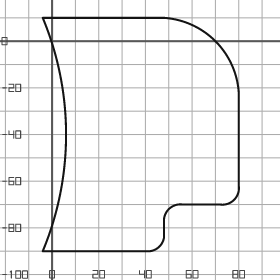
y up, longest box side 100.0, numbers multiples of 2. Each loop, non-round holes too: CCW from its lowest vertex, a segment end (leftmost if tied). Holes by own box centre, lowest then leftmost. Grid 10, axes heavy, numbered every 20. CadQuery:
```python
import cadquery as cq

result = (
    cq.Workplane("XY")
    .moveTo(-4.0, -90.0)
    .lineTo(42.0, -90.0)
    .threePointArc((46.0, -88.0), (48.0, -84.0))
    .lineTo(48.0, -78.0)
    .threePointArc((50.0, -72.0), (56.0, -70.0))
    .lineTo(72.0, -70.0)
    .threePointArc((78.0, -68.0), (80.0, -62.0))
    .lineTo(80.0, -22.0)
    .threePointArc((70.0, 0.0), (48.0, 10.0))
    .lineTo(-4.0, 10.0)
    .threePointArc((6.0, -40.0), (-4.0, -90.0))
    .close()
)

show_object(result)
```